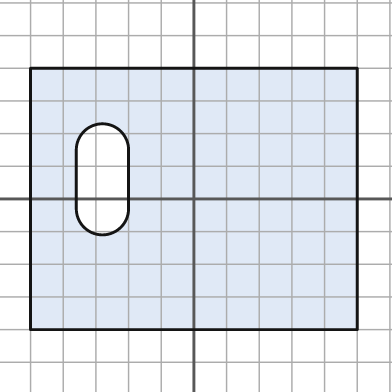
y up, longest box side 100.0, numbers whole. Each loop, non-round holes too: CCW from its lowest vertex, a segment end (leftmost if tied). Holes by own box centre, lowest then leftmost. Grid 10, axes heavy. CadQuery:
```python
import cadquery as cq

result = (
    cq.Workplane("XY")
    .moveTo(-50.0, -40.0)
    .lineTo(50.0, -40.0)
    .lineTo(50.0, 40.0)
    .lineTo(-50.0, 40.0)
    .close()
    .moveTo(-36.0, -3.0)
    .threePointArc((-28.0, -11.0), (-20.0, -3.0))
    .lineTo(-20.0, 15.0)
    .threePointArc((-28.0, 23.0), (-36.0, 15.0))
    .close()
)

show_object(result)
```